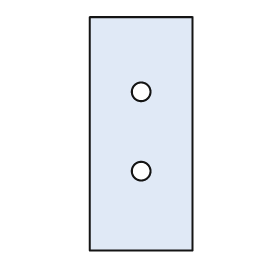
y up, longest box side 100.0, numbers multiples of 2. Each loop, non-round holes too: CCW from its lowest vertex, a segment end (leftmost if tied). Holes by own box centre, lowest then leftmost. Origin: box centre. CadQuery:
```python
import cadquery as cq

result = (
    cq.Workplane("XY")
    .moveTo(-22.0, -50.0)
    .lineTo(22.0, -50.0)
    .lineTo(22.0, 50.0)
    .lineTo(-22.0, 50.0)
    .close()
    .moveTo(0.0, -16.0)
    .circle(4.0)
    .moveTo(0.0, 18.0)
    .circle(4.0)
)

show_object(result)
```